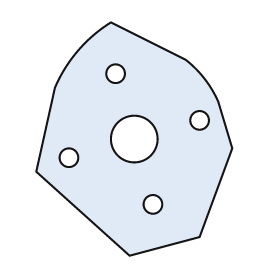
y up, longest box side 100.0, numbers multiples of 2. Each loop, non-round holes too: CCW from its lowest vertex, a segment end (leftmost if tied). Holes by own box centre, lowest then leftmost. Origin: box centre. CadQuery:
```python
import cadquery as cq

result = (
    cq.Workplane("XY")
    .moveTo(-2.0, -50.0)
    .lineTo(28.0, -42.0)
    .lineTo(42.0, -4.0)
    .lineTo(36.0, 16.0)
    .threePointArc((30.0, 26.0), (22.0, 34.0))
    .lineTo(-10.0, 50.0)
    .threePointArc((-24.0, 38.0), (-34.0, 22.0))
    .lineTo(-42.0, -14.0)
    .close()
    .moveTo(8.0, -28.0)
    .circle(4.0)
    .moveTo(-28.0, -8.0)
    .circle(4.0)
    .moveTo(0.0, 0.0)
    .circle(10.0)
    .moveTo(28.0, 8.0)
    .circle(4.0)
    .moveTo(-8.0, 28.0)
    .circle(4.0)
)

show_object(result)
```